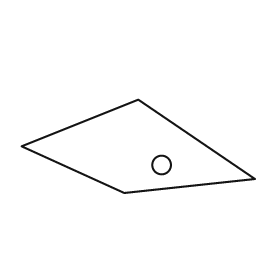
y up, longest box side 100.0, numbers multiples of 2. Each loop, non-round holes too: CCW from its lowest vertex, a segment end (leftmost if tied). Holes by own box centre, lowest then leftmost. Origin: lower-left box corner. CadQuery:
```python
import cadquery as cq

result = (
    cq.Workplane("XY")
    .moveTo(44.0, 0.0)
    .lineTo(100.0, 6.0)
    .lineTo(50.0, 40.0)
    .lineTo(0.0, 20.0)
    .close()
    .moveTo(60.0, 12.0)
    .circle(4.0)
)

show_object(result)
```